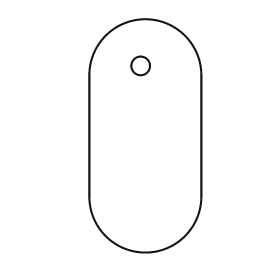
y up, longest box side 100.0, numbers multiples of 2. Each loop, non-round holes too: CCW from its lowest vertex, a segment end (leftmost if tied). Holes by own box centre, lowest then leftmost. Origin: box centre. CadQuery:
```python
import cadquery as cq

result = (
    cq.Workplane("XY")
    .moveTo(-24.0, -26.0)
    .threePointArc((0.0, -50.0), (24.0, -26.0))
    .lineTo(24.0, 26.0)
    .threePointArc((0.0, 50.0), (-24.0, 26.0))
    .close()
    .moveTo(-2.0, 30.0)
    .circle(4.0)
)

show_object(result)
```